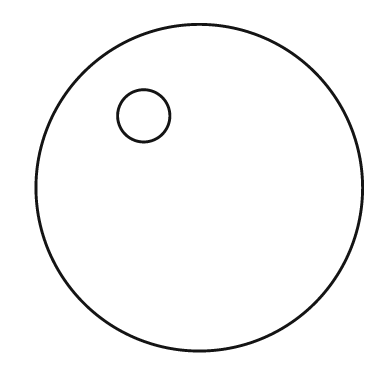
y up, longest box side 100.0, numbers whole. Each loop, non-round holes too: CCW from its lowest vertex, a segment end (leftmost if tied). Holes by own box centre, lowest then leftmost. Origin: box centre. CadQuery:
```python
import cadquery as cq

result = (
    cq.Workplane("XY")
    .moveTo(0.0, 0.0)
    .circle(50.0)
    .moveTo(-17.0, 22.0)
    .circle(8.0)
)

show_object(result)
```